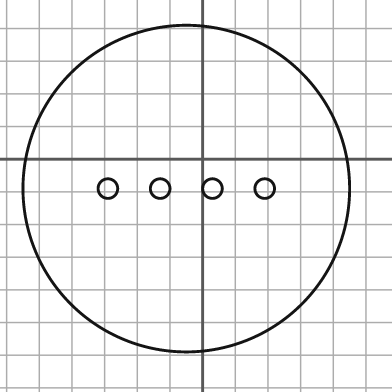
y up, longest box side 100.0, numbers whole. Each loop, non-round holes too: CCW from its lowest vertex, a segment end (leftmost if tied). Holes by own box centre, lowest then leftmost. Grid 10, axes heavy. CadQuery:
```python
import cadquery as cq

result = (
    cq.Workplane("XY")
    .moveTo(-5.0, -9.0)
    .circle(50.0)
    .moveTo(-29.0, -9.0)
    .circle(3.0)
    .moveTo(-13.0, -9.0)
    .circle(3.0)
    .moveTo(3.0, -9.0)
    .circle(3.0)
    .moveTo(19.0, -9.0)
    .circle(3.0)
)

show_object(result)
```